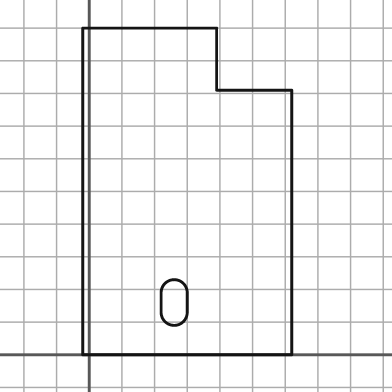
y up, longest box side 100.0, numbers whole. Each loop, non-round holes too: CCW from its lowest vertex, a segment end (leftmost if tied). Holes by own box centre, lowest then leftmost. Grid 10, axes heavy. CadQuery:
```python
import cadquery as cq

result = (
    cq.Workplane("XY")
    .moveTo(-2.0, 0.0)
    .lineTo(62.0, 0.0)
    .lineTo(62.0, 81.0)
    .lineTo(39.0, 81.0)
    .lineTo(39.0, 100.0)
    .lineTo(-2.0, 100.0)
    .close()
    .moveTo(22.0, 13.0)
    .threePointArc((26.0, 9.0), (30.0, 13.0))
    .lineTo(30.0, 19.0)
    .threePointArc((26.0, 23.0), (22.0, 19.0))
    .close()
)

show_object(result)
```